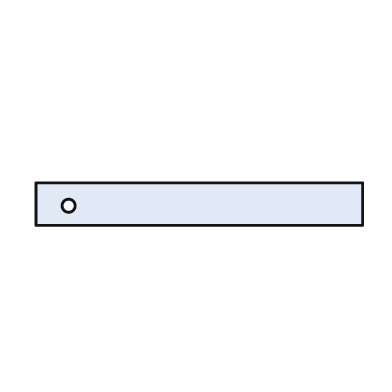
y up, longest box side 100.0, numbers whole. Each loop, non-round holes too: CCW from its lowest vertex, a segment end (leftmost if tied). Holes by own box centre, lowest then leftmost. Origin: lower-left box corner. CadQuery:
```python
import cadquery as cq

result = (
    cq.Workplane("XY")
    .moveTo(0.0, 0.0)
    .lineTo(100.0, 0.0)
    .lineTo(100.0, 13.0)
    .lineTo(0.0, 13.0)
    .close()
    .moveTo(10.0, 6.0)
    .circle(2.0)
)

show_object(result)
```